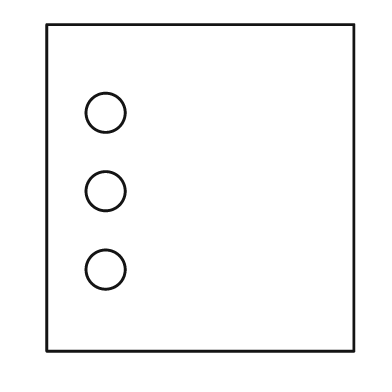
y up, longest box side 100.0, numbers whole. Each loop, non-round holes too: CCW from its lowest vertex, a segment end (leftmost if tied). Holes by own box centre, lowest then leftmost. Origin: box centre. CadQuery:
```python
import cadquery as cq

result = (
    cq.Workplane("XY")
    .moveTo(-47.0, -50.0)
    .lineTo(47.0, -50.0)
    .lineTo(47.0, 50.0)
    .lineTo(-47.0, 50.0)
    .close()
    .moveTo(-29.0, -25.0)
    .circle(6.0)
    .moveTo(-29.0, -1.0)
    .circle(6.0)
    .moveTo(-29.0, 23.0)
    .circle(6.0)
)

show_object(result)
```